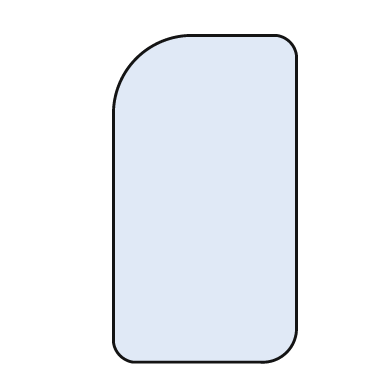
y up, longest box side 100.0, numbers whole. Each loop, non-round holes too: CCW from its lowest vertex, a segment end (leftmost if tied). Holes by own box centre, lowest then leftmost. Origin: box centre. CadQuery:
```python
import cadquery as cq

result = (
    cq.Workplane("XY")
    .moveTo(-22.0, -50.0)
    .lineTo(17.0, -50.0)
    .threePointArc((25.0, -47.0), (28.0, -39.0))
    .lineTo(28.0, 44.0)
    .threePointArc((26.0, 48.0), (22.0, 50.0))
    .lineTo(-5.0, 50.0)
    .threePointArc((-21.0, 43.0), (-28.0, 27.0))
    .lineTo(-28.0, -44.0)
    .threePointArc((-26.0, -48.0), (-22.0, -50.0))
    .close()
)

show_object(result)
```